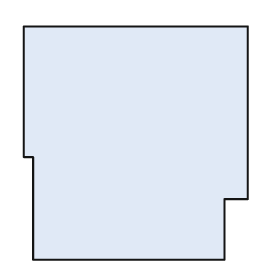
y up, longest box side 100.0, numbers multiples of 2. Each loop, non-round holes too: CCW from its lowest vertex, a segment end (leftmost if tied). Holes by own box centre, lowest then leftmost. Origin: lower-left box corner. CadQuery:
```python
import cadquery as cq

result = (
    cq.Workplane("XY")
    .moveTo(4.0, 0.0)
    .lineTo(86.0, 0.0)
    .lineTo(86.0, 26.0)
    .lineTo(96.0, 26.0)
    .lineTo(96.0, 100.0)
    .lineTo(0.0, 100.0)
    .lineTo(0.0, 44.0)
    .lineTo(4.0, 44.0)
    .close()
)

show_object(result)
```